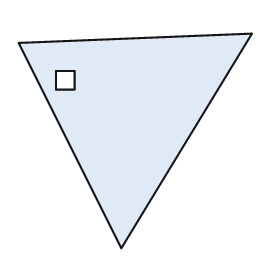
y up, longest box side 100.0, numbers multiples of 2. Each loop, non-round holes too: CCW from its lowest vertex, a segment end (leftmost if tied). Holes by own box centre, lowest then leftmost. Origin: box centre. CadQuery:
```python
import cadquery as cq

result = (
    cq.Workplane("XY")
    .moveTo(-6.0, -46.0)
    .lineTo(50.0, 46.0)
    .lineTo(-50.0, 42.0)
    .close()
    .moveTo(-34.0, 22.0)
    .lineTo(-26.0, 22.0)
    .lineTo(-26.0, 30.0)
    .lineTo(-34.0, 30.0)
    .close()
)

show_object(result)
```